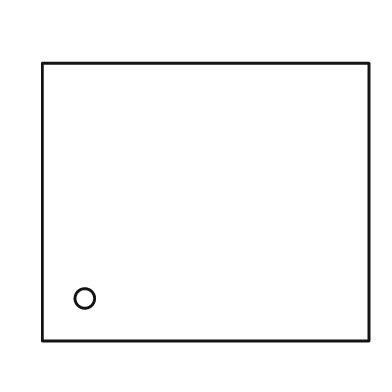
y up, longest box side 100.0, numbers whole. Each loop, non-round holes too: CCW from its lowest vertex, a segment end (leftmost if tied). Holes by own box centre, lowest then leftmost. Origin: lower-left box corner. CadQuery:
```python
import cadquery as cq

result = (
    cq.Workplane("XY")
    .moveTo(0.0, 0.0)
    .lineTo(100.0, 0.0)
    .lineTo(100.0, 85.0)
    .lineTo(0.0, 85.0)
    .close()
    .moveTo(13.0, 13.0)
    .circle(3.0)
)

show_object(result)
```